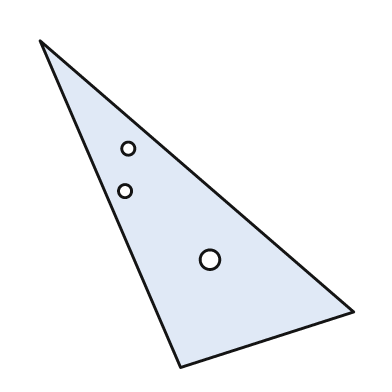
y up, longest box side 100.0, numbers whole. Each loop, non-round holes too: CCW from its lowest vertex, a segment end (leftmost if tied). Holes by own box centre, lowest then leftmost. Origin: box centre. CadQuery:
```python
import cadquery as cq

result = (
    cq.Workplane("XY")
    .moveTo(-5.0, -50.0)
    .lineTo(48.0, -33.0)
    .lineTo(-48.0, 50.0)
    .close()
    .moveTo(4.0, -17.0)
    .circle(3.0)
    .moveTo(-22.0, 4.0)
    .circle(2.0)
    .moveTo(-21.0, 17.0)
    .circle(2.0)
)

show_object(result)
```